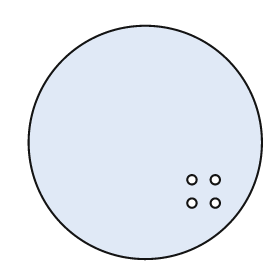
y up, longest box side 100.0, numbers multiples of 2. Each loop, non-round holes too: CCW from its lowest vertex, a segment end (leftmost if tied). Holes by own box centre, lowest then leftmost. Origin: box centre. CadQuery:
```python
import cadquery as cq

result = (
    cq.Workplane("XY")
    .moveTo(0.0, 0.0)
    .circle(50.0)
    .moveTo(20.0, -26.0)
    .circle(2.0)
    .moveTo(30.0, -26.0)
    .circle(2.0)
    .moveTo(20.0, -16.0)
    .circle(2.0)
    .moveTo(30.0, -16.0)
    .circle(2.0)
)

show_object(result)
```